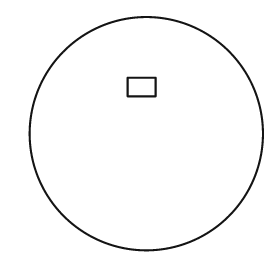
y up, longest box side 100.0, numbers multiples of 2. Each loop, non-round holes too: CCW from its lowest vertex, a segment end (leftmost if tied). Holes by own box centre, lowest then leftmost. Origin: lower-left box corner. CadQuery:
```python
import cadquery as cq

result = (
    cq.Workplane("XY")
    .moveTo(50.0, 50.0)
    .circle(50.0)
    .moveTo(42.0, 66.0)
    .lineTo(54.0, 66.0)
    .lineTo(54.0, 74.0)
    .lineTo(42.0, 74.0)
    .close()
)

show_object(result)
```